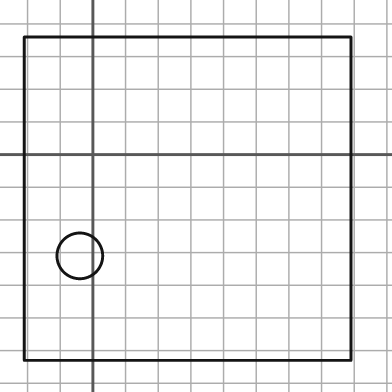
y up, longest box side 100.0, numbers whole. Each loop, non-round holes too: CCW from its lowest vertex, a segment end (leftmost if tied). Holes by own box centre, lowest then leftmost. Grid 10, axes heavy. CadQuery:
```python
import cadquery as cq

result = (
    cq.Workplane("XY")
    .moveTo(-21.0, -63.0)
    .lineTo(79.0, -63.0)
    .lineTo(79.0, 36.0)
    .lineTo(-21.0, 36.0)
    .close()
    .moveTo(-4.0, -31.0)
    .circle(7.0)
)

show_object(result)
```